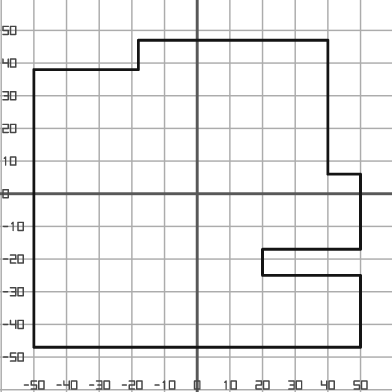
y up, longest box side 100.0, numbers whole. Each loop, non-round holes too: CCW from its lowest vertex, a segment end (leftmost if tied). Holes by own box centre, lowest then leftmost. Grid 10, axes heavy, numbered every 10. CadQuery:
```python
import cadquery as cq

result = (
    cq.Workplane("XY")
    .moveTo(-50.0, -47.0)
    .lineTo(50.0, -47.0)
    .lineTo(50.0, -25.0)
    .lineTo(20.0, -25.0)
    .lineTo(20.0, -17.0)
    .lineTo(50.0, -17.0)
    .lineTo(50.0, 6.0)
    .lineTo(40.0, 6.0)
    .lineTo(40.0, 47.0)
    .lineTo(-18.0, 47.0)
    .lineTo(-18.0, 38.0)
    .lineTo(-50.0, 38.0)
    .close()
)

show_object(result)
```